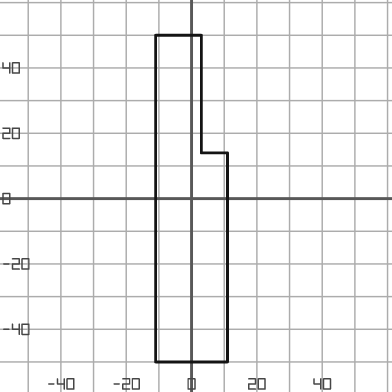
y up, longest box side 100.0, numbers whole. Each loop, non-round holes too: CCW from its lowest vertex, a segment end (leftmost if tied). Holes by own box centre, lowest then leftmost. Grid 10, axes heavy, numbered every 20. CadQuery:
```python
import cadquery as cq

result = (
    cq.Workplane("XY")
    .moveTo(-11.0, -50.0)
    .lineTo(11.0, -50.0)
    .lineTo(11.0, 14.0)
    .lineTo(3.0, 14.0)
    .lineTo(3.0, 50.0)
    .lineTo(-11.0, 50.0)
    .close()
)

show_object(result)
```